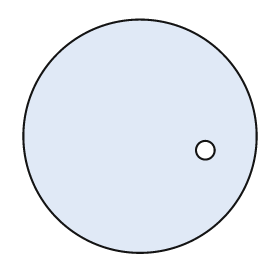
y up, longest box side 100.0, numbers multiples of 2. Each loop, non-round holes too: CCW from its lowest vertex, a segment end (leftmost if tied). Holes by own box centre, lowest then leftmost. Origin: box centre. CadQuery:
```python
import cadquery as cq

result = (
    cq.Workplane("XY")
    .moveTo(0.0, 0.0)
    .circle(50.0)
    .moveTo(28.0, -6.0)
    .circle(4.0)
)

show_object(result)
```